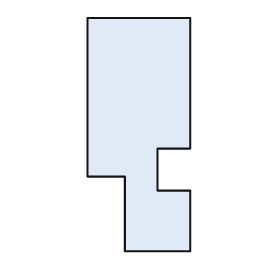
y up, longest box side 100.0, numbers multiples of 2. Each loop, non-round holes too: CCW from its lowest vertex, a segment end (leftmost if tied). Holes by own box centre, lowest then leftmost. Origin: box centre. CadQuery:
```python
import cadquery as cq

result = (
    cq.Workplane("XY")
    .moveTo(-6.0, -50.0)
    .lineTo(22.0, -50.0)
    .lineTo(22.0, -24.0)
    .lineTo(8.0, -24.0)
    .lineTo(8.0, -6.0)
    .lineTo(22.0, -6.0)
    .lineTo(22.0, 50.0)
    .lineTo(-22.0, 50.0)
    .lineTo(-22.0, -18.0)
    .lineTo(-6.0, -18.0)
    .close()
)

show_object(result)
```